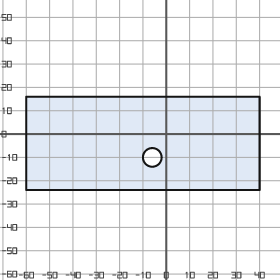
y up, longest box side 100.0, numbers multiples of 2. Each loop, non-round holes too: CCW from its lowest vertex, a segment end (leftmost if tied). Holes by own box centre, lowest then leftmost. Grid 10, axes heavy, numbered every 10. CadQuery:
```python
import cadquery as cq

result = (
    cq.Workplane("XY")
    .moveTo(-60.0, -24.0)
    .lineTo(40.0, -24.0)
    .lineTo(40.0, 16.0)
    .lineTo(-60.0, 16.0)
    .close()
    .moveTo(-6.0, -10.0)
    .circle(4.0)
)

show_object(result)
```